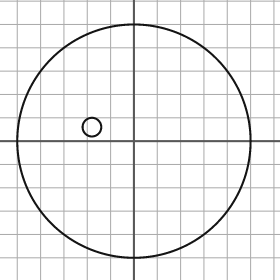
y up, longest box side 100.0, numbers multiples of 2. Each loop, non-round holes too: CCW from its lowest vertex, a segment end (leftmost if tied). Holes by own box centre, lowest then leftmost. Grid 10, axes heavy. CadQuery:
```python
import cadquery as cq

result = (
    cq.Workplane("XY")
    .moveTo(0.0, 0.0)
    .circle(50.0)
    .moveTo(-18.0, 6.0)
    .circle(4.0)
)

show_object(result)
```